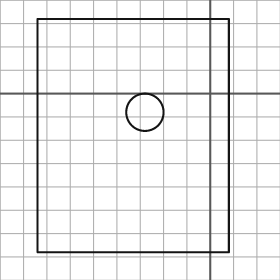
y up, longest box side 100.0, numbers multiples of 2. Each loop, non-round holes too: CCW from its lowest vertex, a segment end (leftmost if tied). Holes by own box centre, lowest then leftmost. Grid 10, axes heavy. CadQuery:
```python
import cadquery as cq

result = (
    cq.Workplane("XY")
    .moveTo(-74.0, -68.0)
    .lineTo(8.0, -68.0)
    .lineTo(8.0, 32.0)
    .lineTo(-74.0, 32.0)
    .close()
    .moveTo(-28.0, -8.0)
    .circle(8.0)
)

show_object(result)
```